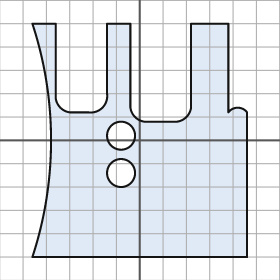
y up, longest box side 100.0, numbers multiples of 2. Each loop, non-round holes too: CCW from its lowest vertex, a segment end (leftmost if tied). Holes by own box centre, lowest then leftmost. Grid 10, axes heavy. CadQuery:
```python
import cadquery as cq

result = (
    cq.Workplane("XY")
    .moveTo(-46.0, -50.0)
    .lineTo(46.0, -50.0)
    .lineTo(46.0, 12.0)
    .threePointArc((42.0, 14.0), (38.0, 12.0))
    .lineTo(38.0, 50.0)
    .lineTo(22.0, 50.0)
    .lineTo(22.0, 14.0)
    .threePointArc((20.0, 10.0), (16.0, 8.0))
    .lineTo(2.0, 8.0)
    .threePointArc((-2.0, 10.0), (-4.0, 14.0))
    .lineTo(-4.0, 50.0)
    .lineTo(-14.0, 50.0)
    .lineTo(-14.0, 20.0)
    .threePointArc((-16.0, 14.0), (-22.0, 12.0))
    .lineTo(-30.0, 12.0)
    .threePointArc((-34.0, 14.0), (-36.0, 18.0))
    .lineTo(-36.0, 50.0)
    .lineTo(-46.0, 50.0)
    .threePointArc((-38.0, 0.0), (-46.0, -50.0))
    .close()
    .moveTo(-8.0, -14.0)
    .circle(6.0)
    .moveTo(-8.0, 2.0)
    .circle(6.0)
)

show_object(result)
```